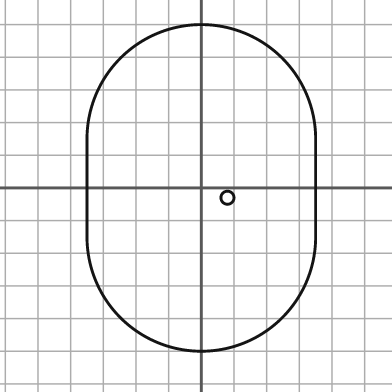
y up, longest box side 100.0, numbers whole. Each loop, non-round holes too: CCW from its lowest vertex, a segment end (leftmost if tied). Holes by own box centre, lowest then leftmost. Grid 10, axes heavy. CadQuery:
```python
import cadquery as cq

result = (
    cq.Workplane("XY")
    .moveTo(-35.0, -15.0)
    .threePointArc((0.0, -50.0), (35.0, -15.0))
    .lineTo(35.0, 15.0)
    .threePointArc((0.0, 50.0), (-35.0, 15.0))
    .close()
    .moveTo(8.0, -3.0)
    .circle(2.0)
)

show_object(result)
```